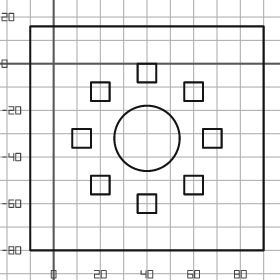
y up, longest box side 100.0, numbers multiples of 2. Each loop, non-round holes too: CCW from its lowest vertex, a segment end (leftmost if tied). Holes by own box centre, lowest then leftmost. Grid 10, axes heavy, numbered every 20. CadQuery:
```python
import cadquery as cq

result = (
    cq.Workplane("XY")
    .moveTo(-10.0, -80.0)
    .lineTo(90.0, -80.0)
    .lineTo(90.0, 16.0)
    .lineTo(-10.0, 16.0)
    .close()
    .moveTo(36.0, -64.0)
    .lineTo(44.0, -64.0)
    .lineTo(44.0, -56.0)
    .lineTo(36.0, -56.0)
    .close()
    .moveTo(16.0, -56.0)
    .lineTo(24.0, -56.0)
    .lineTo(24.0, -48.0)
    .lineTo(16.0, -48.0)
    .close()
    .moveTo(56.0, -56.0)
    .lineTo(64.0, -56.0)
    .lineTo(64.0, -48.0)
    .lineTo(56.0, -48.0)
    .close()
    .moveTo(8.0, -36.0)
    .lineTo(16.0, -36.0)
    .lineTo(16.0, -28.0)
    .lineTo(8.0, -28.0)
    .close()
    .moveTo(40.0, -32.0)
    .circle(14.0)
    .moveTo(64.0, -36.0)
    .lineTo(72.0, -36.0)
    .lineTo(72.0, -28.0)
    .lineTo(64.0, -28.0)
    .close()
    .moveTo(16.0, -16.0)
    .lineTo(24.0, -16.0)
    .lineTo(24.0, -8.0)
    .lineTo(16.0, -8.0)
    .close()
    .moveTo(56.0, -16.0)
    .lineTo(64.0, -16.0)
    .lineTo(64.0, -8.0)
    .lineTo(56.0, -8.0)
    .close()
    .moveTo(36.0, -8.0)
    .lineTo(44.0, -8.0)
    .lineTo(44.0, 0.0)
    .lineTo(36.0, 0.0)
    .close()
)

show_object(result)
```